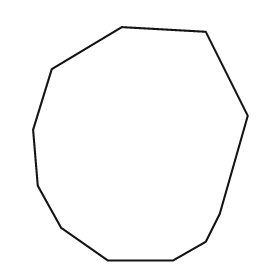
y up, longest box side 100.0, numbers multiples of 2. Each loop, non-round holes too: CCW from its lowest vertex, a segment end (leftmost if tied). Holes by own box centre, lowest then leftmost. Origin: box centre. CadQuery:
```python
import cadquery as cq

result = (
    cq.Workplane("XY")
    .moveTo(-14.0, -50.0)
    .lineTo(14.0, -50.0)
    .lineTo(28.0, -42.0)
    .lineTo(34.0, -30.0)
    .lineTo(46.0, 12.0)
    .lineTo(28.0, 48.0)
    .lineTo(-8.0, 50.0)
    .lineTo(-38.0, 32.0)
    .lineTo(-46.0, 6.0)
    .lineTo(-44.0, -18.0)
    .lineTo(-34.0, -36.0)
    .close()
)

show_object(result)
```